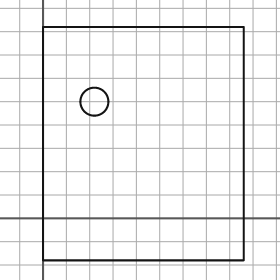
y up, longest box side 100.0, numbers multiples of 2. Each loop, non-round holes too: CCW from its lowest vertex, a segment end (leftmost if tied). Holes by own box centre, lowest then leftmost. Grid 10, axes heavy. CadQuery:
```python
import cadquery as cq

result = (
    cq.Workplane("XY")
    .moveTo(0.0, -18.0)
    .lineTo(86.0, -18.0)
    .lineTo(86.0, 82.0)
    .lineTo(0.0, 82.0)
    .close()
    .moveTo(22.0, 50.0)
    .circle(6.0)
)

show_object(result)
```